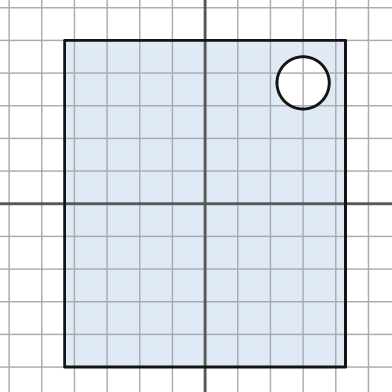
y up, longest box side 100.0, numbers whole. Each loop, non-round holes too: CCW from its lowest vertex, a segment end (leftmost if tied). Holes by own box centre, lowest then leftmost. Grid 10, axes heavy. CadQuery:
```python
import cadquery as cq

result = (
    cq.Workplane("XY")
    .moveTo(-43.0, -50.0)
    .lineTo(43.0, -50.0)
    .lineTo(43.0, 50.0)
    .lineTo(-43.0, 50.0)
    .close()
    .moveTo(30.0, 37.0)
    .circle(8.0)
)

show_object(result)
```